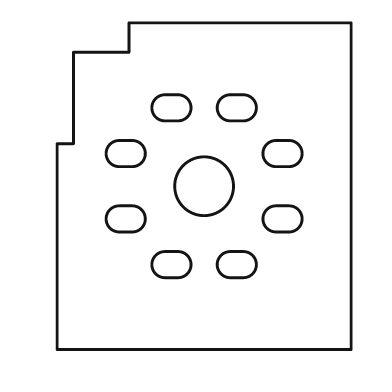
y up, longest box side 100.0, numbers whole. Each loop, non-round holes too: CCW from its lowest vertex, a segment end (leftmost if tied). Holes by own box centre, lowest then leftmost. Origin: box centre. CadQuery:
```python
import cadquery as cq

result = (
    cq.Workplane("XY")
    .moveTo(-45.0, -50.0)
    .lineTo(45.0, -50.0)
    .lineTo(45.0, 50.0)
    .lineTo(-23.0, 50.0)
    .lineTo(-23.0, 41.0)
    .lineTo(-40.0, 41.0)
    .lineTo(-40.0, 13.0)
    .lineTo(-45.0, 13.0)
    .close()
    .moveTo(-12.0, -28.0)
    .lineTo(-8.0, -28.0)
    .threePointArc((-4.0, -24.0), (-8.0, -20.0))
    .lineTo(-12.0, -20.0)
    .threePointArc((-16.0, -24.0), (-12.0, -28.0))
    .close()
    .moveTo(8.0, -28.0)
    .lineTo(12.0, -28.0)
    .threePointArc((16.0, -24.0), (12.0, -20.0))
    .lineTo(8.0, -20.0)
    .threePointArc((4.0, -24.0), (8.0, -28.0))
    .close()
    .moveTo(-26.0, -14.0)
    .lineTo(-22.0, -14.0)
    .threePointArc((-18.0, -10.0), (-22.0, -6.0))
    .lineTo(-26.0, -6.0)
    .threePointArc((-30.0, -10.0), (-26.0, -14.0))
    .close()
    .moveTo(22.0, -14.0)
    .lineTo(26.0, -14.0)
    .threePointArc((30.0, -10.0), (26.0, -6.0))
    .lineTo(22.0, -6.0)
    .threePointArc((18.0, -10.0), (22.0, -14.0))
    .close()
    .moveTo(0.0, 0.0)
    .circle(9.0)
    .moveTo(-26.0, 6.0)
    .lineTo(-22.0, 6.0)
    .threePointArc((-18.0, 10.0), (-22.0, 14.0))
    .lineTo(-26.0, 14.0)
    .threePointArc((-30.0, 10.0), (-26.0, 6.0))
    .close()
    .moveTo(22.0, 6.0)
    .lineTo(26.0, 6.0)
    .threePointArc((30.0, 10.0), (26.0, 14.0))
    .lineTo(22.0, 14.0)
    .threePointArc((18.0, 10.0), (22.0, 6.0))
    .close()
    .moveTo(-12.0, 20.0)
    .lineTo(-8.0, 20.0)
    .threePointArc((-4.0, 24.0), (-8.0, 28.0))
    .lineTo(-12.0, 28.0)
    .threePointArc((-16.0, 24.0), (-12.0, 20.0))
    .close()
    .moveTo(8.0, 20.0)
    .lineTo(12.0, 20.0)
    .threePointArc((16.0, 24.0), (12.0, 28.0))
    .lineTo(8.0, 28.0)
    .threePointArc((4.0, 24.0), (8.0, 20.0))
    .close()
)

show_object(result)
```